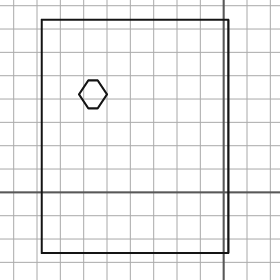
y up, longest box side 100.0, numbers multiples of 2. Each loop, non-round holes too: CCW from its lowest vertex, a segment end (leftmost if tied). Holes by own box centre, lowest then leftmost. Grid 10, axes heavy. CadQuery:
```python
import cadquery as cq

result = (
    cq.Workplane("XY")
    .moveTo(-78.0, -26.0)
    .lineTo(2.0, -26.0)
    .lineTo(2.0, 74.0)
    .lineTo(-78.0, 74.0)
    .close()
    .moveTo(-58.0, 36.0)
    .lineTo(-54.0, 36.0)
    .lineTo(-50.0, 42.0)
    .lineTo(-54.0, 48.0)
    .lineTo(-58.0, 48.0)
    .lineTo(-62.0, 42.0)
    .close()
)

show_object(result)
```